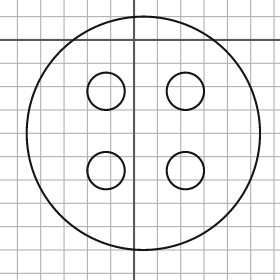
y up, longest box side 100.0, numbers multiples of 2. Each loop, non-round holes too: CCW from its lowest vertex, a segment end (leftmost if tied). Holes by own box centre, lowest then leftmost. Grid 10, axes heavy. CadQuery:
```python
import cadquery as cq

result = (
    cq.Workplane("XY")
    .moveTo(4.0, -40.0)
    .circle(50.0)
    .moveTo(-12.0, -56.0)
    .circle(8.0)
    .moveTo(22.0, -56.0)
    .circle(8.0)
    .moveTo(-12.0, -22.0)
    .circle(8.0)
    .moveTo(22.0, -22.0)
    .circle(8.0)
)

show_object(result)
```